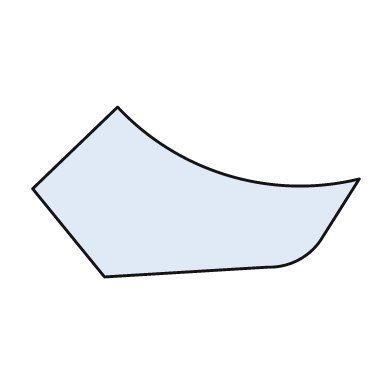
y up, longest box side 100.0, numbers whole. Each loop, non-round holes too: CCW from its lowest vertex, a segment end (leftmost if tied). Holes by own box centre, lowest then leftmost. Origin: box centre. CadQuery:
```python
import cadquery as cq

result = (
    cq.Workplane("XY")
    .moveTo(-28.0, -26.0)
    .lineTo(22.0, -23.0)
    .threePointArc((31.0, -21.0), (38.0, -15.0))
    .lineTo(50.0, 4.0)
    .threePointArc((10.0, 5.0), (-24.0, 26.0))
    .lineTo(-50.0, 1.0)
    .close()
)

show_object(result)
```